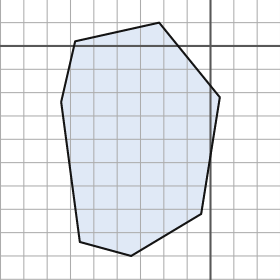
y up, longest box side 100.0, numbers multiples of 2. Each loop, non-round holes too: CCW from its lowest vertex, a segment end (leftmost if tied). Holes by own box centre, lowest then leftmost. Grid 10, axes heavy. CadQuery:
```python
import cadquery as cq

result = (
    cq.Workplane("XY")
    .moveTo(-34.0, -90.0)
    .lineTo(-4.0, -72.0)
    .lineTo(4.0, -22.0)
    .lineTo(-22.0, 10.0)
    .lineTo(-58.0, 2.0)
    .lineTo(-64.0, -24.0)
    .lineTo(-56.0, -84.0)
    .close()
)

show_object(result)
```